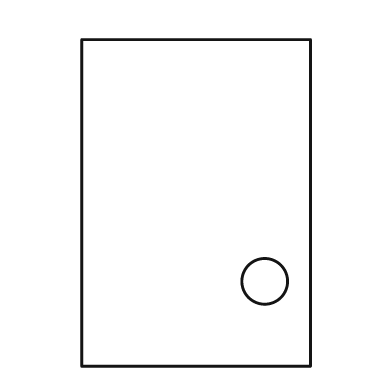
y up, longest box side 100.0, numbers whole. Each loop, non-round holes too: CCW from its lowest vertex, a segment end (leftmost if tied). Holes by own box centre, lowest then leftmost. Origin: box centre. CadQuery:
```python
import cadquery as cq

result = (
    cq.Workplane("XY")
    .moveTo(-35.0, -50.0)
    .lineTo(35.0, -50.0)
    .lineTo(35.0, 50.0)
    .lineTo(-35.0, 50.0)
    .close()
    .moveTo(21.0, -24.0)
    .circle(7.0)
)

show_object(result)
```